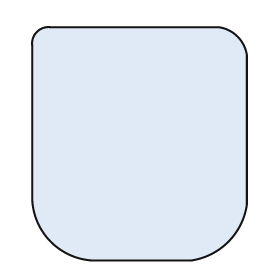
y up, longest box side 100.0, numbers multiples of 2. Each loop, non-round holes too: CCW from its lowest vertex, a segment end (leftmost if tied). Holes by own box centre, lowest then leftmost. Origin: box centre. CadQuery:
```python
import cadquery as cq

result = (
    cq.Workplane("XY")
    .moveTo(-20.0, -50.0)
    .lineTo(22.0, -50.0)
    .threePointArc((38.0, -42.0), (46.0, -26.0))
    .lineTo(46.0, 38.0)
    .threePointArc((42.0, 46.0), (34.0, 50.0))
    .lineTo(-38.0, 50.0)
    .threePointArc((-44.0, 48.0), (-46.0, 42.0))
    .lineTo(-46.0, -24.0)
    .threePointArc((-38.0, -42.0), (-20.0, -50.0))
    .close()
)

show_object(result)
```